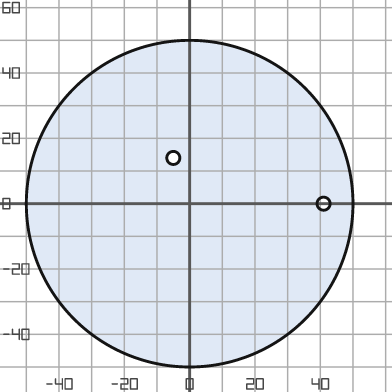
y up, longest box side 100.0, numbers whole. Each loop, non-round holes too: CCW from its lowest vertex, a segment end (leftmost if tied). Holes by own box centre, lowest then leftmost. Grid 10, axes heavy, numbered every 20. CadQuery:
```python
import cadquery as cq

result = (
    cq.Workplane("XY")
    .moveTo(0.0, 0.0)
    .circle(50.0)
    .moveTo(41.0, 0.0)
    .circle(2.0)
    .moveTo(-5.0, 14.0)
    .circle(2.0)
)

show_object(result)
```